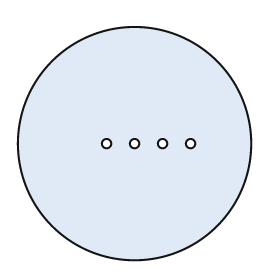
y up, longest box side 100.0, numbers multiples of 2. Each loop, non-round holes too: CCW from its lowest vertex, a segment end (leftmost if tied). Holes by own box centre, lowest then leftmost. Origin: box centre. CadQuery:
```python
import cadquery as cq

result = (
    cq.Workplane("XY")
    .moveTo(0.0, 0.0)
    .circle(50.0)
    .moveTo(-12.0, 0.0)
    .circle(2.0)
    .moveTo(0.0, 0.0)
    .circle(2.0)
    .moveTo(12.0, 0.0)
    .circle(2.0)
    .moveTo(24.0, 0.0)
    .circle(2.0)
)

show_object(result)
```